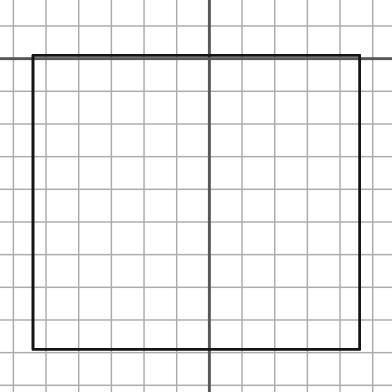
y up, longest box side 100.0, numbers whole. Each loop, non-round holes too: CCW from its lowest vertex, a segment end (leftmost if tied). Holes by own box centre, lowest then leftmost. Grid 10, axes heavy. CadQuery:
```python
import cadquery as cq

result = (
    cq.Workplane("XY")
    .moveTo(-54.0, -89.0)
    .lineTo(46.0, -89.0)
    .lineTo(46.0, 1.0)
    .lineTo(-54.0, 1.0)
    .close()
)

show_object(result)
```